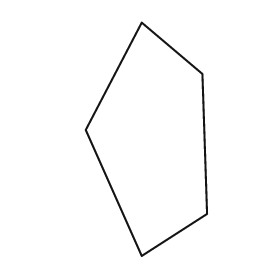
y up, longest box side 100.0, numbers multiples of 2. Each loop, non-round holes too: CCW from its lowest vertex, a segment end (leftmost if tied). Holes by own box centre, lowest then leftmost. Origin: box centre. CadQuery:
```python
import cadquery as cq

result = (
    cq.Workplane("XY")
    .moveTo(-2.0, -50.0)
    .lineTo(26.0, -32.0)
    .lineTo(24.0, 28.0)
    .lineTo(-2.0, 50.0)
    .lineTo(-26.0, 4.0)
    .close()
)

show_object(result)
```